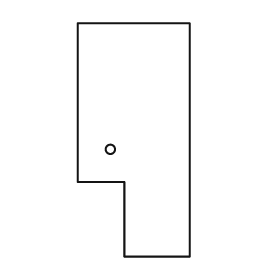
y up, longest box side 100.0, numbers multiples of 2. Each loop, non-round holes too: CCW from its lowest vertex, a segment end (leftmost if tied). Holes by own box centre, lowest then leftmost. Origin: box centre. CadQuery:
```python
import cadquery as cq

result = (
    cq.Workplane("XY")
    .moveTo(-4.0, -50.0)
    .lineTo(24.0, -50.0)
    .lineTo(24.0, 50.0)
    .lineTo(-24.0, 50.0)
    .lineTo(-24.0, -18.0)
    .lineTo(-4.0, -18.0)
    .close()
    .moveTo(-10.0, -4.0)
    .circle(2.0)
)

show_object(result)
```